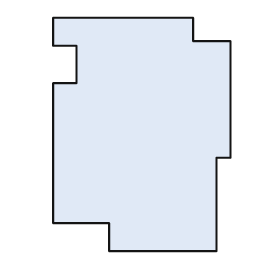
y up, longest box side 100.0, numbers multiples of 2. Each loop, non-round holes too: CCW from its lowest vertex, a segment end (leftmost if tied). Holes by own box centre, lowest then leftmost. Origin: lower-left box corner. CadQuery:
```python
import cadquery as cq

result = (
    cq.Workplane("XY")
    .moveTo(24.0, 0.0)
    .lineTo(70.0, 0.0)
    .lineTo(70.0, 40.0)
    .lineTo(76.0, 40.0)
    .lineTo(76.0, 90.0)
    .lineTo(60.0, 90.0)
    .lineTo(60.0, 100.0)
    .lineTo(0.0, 100.0)
    .lineTo(0.0, 88.0)
    .lineTo(10.0, 88.0)
    .lineTo(10.0, 72.0)
    .lineTo(0.0, 72.0)
    .lineTo(0.0, 12.0)
    .lineTo(24.0, 12.0)
    .close()
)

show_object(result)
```